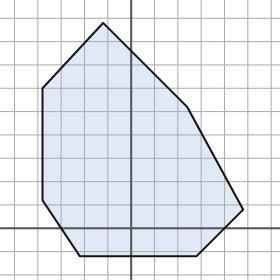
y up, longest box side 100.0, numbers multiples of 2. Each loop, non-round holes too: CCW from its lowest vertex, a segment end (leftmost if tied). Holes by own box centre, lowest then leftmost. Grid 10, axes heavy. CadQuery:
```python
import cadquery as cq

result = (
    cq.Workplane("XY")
    .moveTo(-22.0, -12.0)
    .lineTo(28.0, -12.0)
    .lineTo(48.0, 8.0)
    .lineTo(24.0, 52.0)
    .lineTo(-12.0, 88.0)
    .lineTo(-38.0, 60.0)
    .lineTo(-38.0, 12.0)
    .close()
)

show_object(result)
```